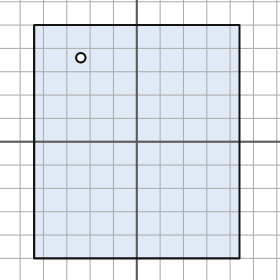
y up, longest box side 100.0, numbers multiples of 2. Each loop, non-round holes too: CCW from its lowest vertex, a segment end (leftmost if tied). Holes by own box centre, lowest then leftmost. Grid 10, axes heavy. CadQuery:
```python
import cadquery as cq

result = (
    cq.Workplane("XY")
    .moveTo(-44.0, -50.0)
    .lineTo(44.0, -50.0)
    .lineTo(44.0, 50.0)
    .lineTo(-44.0, 50.0)
    .close()
    .moveTo(-24.0, 36.0)
    .circle(2.0)
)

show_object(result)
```